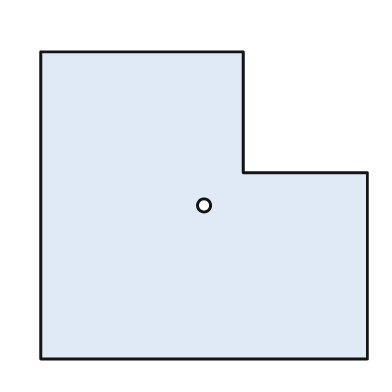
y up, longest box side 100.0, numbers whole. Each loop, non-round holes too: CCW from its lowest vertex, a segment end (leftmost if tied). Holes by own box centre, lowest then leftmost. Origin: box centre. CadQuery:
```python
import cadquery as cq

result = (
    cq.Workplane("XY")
    .moveTo(-50.0, -47.0)
    .lineTo(50.0, -47.0)
    .lineTo(50.0, 10.0)
    .lineTo(12.0, 10.0)
    .lineTo(12.0, 47.0)
    .lineTo(-50.0, 47.0)
    .close()
    .moveTo(0.0, 0.0)
    .circle(2.0)
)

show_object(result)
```